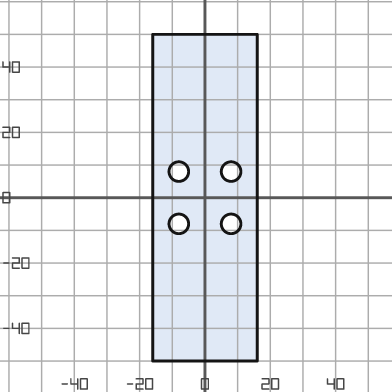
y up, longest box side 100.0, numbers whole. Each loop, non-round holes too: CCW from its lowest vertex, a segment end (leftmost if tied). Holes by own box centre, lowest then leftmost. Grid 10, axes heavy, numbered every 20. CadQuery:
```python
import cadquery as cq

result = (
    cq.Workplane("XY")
    .moveTo(-16.0, -50.0)
    .lineTo(16.0, -50.0)
    .lineTo(16.0, 50.0)
    .lineTo(-16.0, 50.0)
    .close()
    .moveTo(-8.0, -8.0)
    .circle(3.0)
    .moveTo(8.0, -8.0)
    .circle(3.0)
    .moveTo(-8.0, 8.0)
    .circle(3.0)
    .moveTo(8.0, 8.0)
    .circle(3.0)
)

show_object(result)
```